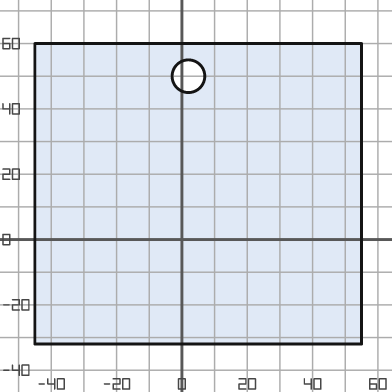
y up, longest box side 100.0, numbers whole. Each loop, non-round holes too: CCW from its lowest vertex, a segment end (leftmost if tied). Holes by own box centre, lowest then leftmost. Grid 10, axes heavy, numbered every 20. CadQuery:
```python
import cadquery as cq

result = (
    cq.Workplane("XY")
    .moveTo(-45.0, -32.0)
    .lineTo(55.0, -32.0)
    .lineTo(55.0, 60.0)
    .lineTo(-45.0, 60.0)
    .close()
    .moveTo(2.0, 50.0)
    .circle(5.0)
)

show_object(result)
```